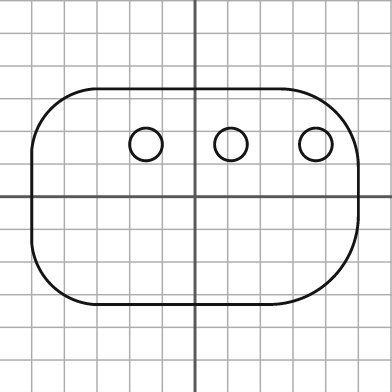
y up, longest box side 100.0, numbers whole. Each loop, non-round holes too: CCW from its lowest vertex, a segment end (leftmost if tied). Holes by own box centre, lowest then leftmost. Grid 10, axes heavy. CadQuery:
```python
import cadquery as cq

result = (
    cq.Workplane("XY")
    .moveTo(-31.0, -33.0)
    .lineTo(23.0, -33.0)
    .threePointArc((42.0, -25.0), (50.0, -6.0))
    .lineTo(50.0, 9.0)
    .threePointArc((43.0, 26.0), (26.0, 33.0))
    .lineTo(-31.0, 33.0)
    .threePointArc((-44.0, 27.0), (-50.0, 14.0))
    .lineTo(-50.0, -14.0)
    .threePointArc((-44.0, -27.0), (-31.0, -33.0))
    .close()
    .moveTo(-15.0, 16.0)
    .circle(5.0)
    .moveTo(11.0, 16.0)
    .circle(5.0)
    .moveTo(37.0, 16.0)
    .circle(5.0)
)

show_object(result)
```